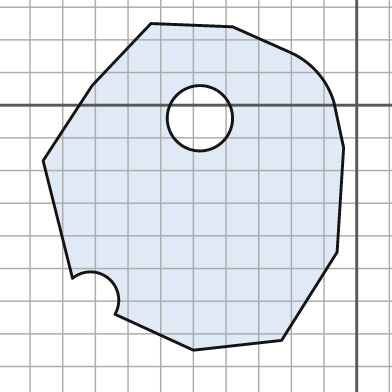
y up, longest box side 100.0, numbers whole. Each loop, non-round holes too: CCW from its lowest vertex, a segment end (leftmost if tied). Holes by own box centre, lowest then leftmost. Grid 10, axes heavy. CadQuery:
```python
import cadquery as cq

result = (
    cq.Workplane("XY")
    .moveTo(-50.0, -75.0)
    .lineTo(-23.0, -72.0)
    .lineTo(-6.0, -45.0)
    .lineTo(-4.0, -13.0)
    .lineTo(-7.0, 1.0)
    .threePointArc((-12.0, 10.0), (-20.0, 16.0))
    .lineTo(-38.0, 24.0)
    .lineTo(-63.0, 25.0)
    .lineTo(-81.0, 6.0)
    .lineTo(-96.0, -17.0)
    .lineTo(-87.0, -53.0)
    .threePointArc((-76.0, -53.0), (-74.0, -64.0))
    .close()
    .moveTo(-48.0, -4.0)
    .circle(10.0)
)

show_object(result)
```